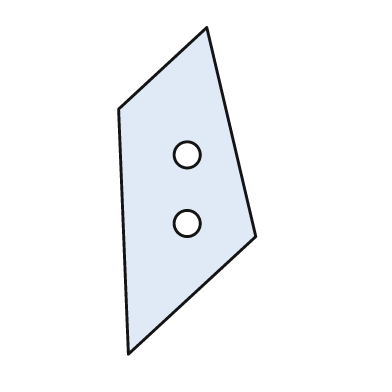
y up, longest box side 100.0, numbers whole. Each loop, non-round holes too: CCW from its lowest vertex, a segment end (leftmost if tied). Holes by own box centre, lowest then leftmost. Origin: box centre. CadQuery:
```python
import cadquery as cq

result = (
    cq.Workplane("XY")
    .moveTo(-18.0, -50.0)
    .lineTo(21.0, -14.0)
    .lineTo(6.0, 50.0)
    .lineTo(-21.0, 25.0)
    .close()
    .moveTo(0.0, -10.0)
    .circle(4.0)
    .moveTo(0.0, 11.0)
    .circle(4.0)
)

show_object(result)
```